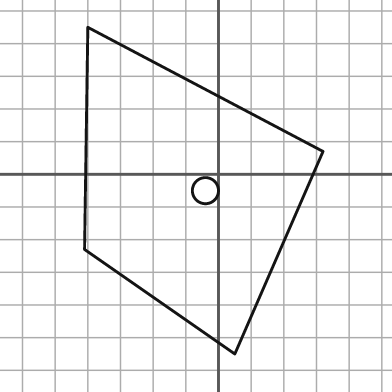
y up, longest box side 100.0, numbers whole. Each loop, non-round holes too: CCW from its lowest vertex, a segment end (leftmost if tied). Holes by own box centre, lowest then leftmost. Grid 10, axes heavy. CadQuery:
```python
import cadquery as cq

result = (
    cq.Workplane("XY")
    .moveTo(5.0, -55.0)
    .lineTo(32.0, 7.0)
    .lineTo(-40.0, 45.0)
    .lineTo(-41.0, -23.0)
    .close()
    .moveTo(-4.0, -5.0)
    .circle(4.0)
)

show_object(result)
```